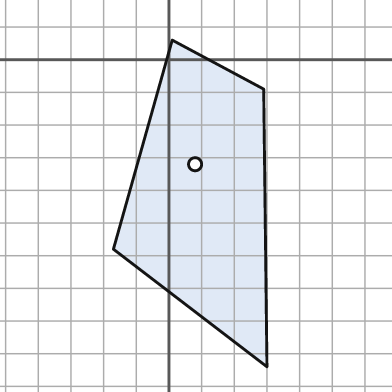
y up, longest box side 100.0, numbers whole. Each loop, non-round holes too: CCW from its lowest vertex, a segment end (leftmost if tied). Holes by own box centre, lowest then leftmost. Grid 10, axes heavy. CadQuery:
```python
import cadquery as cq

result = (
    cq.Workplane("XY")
    .moveTo(30.0, -94.0)
    .lineTo(29.0, -9.0)
    .lineTo(1.0, 6.0)
    .lineTo(-17.0, -58.0)
    .close()
    .moveTo(8.0, -32.0)
    .circle(2.0)
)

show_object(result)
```